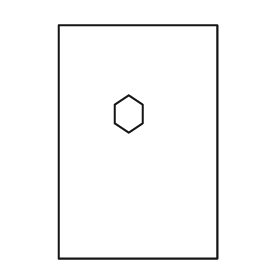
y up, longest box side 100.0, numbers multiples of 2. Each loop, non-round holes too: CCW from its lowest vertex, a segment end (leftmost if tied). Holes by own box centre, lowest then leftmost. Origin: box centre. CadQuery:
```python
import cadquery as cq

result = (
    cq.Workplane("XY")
    .moveTo(-34.0, -50.0)
    .lineTo(34.0, -50.0)
    .lineTo(34.0, 50.0)
    .lineTo(-34.0, 50.0)
    .close()
    .moveTo(-4.0, 4.0)
    .lineTo(2.0, 8.0)
    .lineTo(2.0, 16.0)
    .lineTo(-4.0, 20.0)
    .lineTo(-10.0, 16.0)
    .lineTo(-10.0, 8.0)
    .close()
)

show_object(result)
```